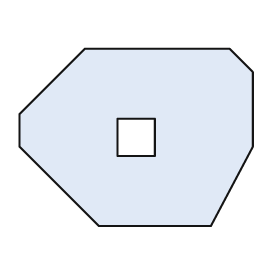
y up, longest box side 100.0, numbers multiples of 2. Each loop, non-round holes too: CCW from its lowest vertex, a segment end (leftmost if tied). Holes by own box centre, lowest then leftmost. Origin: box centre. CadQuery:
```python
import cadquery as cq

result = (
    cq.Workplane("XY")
    .moveTo(-16.0, -38.0)
    .lineTo(32.0, -38.0)
    .lineTo(50.0, -4.0)
    .lineTo(50.0, 28.0)
    .lineTo(40.0, 38.0)
    .lineTo(-22.0, 38.0)
    .lineTo(-50.0, 10.0)
    .lineTo(-50.0, -4.0)
    .close()
    .moveTo(-8.0, -8.0)
    .lineTo(8.0, -8.0)
    .lineTo(8.0, 8.0)
    .lineTo(-8.0, 8.0)
    .close()
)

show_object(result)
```